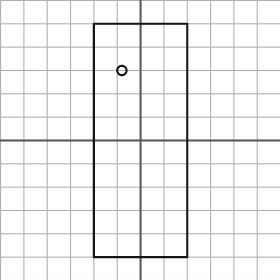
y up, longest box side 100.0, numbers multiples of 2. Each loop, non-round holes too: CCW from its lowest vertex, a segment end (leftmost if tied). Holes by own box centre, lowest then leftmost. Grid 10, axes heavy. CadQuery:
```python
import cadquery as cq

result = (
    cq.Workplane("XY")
    .moveTo(-20.0, -50.0)
    .lineTo(20.0, -50.0)
    .lineTo(20.0, 50.0)
    .lineTo(-20.0, 50.0)
    .close()
    .moveTo(-8.0, 30.0)
    .circle(2.0)
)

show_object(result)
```